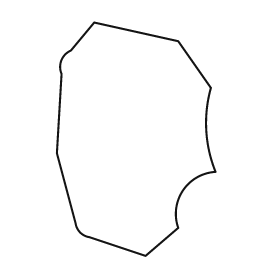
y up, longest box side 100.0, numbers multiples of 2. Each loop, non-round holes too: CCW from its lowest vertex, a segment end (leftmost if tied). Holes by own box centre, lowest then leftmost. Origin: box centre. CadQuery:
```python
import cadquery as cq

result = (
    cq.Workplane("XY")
    .moveTo(4.0, -50.0)
    .lineTo(18.0, -38.0)
    .threePointArc((20.0, -22.0), (34.0, -14.0))
    .threePointArc((30.0, 4.0), (32.0, 22.0))
    .lineTo(18.0, 42.0)
    .lineTo(-18.0, 50.0)
    .lineTo(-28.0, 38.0)
    .threePointArc((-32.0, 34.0), (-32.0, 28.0))
    .lineTo(-34.0, -6.0)
    .lineTo(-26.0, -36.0)
    .threePointArc((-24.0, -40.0), (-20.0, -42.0))
    .close()
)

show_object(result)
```